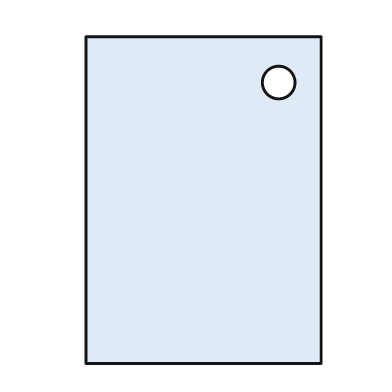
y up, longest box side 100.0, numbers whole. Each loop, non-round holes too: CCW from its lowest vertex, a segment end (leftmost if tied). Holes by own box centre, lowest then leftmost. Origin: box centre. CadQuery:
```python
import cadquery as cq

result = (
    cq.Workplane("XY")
    .moveTo(-36.0, -50.0)
    .lineTo(36.0, -50.0)
    .lineTo(36.0, 50.0)
    .lineTo(-36.0, 50.0)
    .close()
    .moveTo(23.0, 36.0)
    .circle(5.0)
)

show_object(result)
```